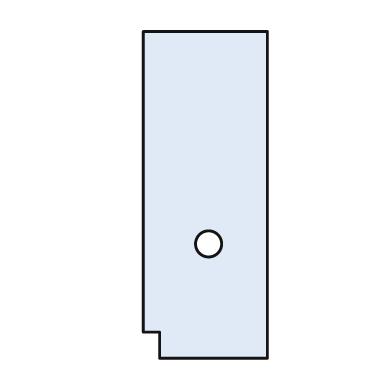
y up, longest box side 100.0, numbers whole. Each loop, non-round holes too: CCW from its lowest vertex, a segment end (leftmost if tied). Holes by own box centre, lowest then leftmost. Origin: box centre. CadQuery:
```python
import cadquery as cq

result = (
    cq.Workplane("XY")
    .moveTo(-14.0, -50.0)
    .lineTo(19.0, -50.0)
    .lineTo(19.0, 50.0)
    .lineTo(-19.0, 50.0)
    .lineTo(-19.0, -42.0)
    .lineTo(-14.0, -42.0)
    .close()
    .moveTo(1.0, -15.0)
    .circle(4.0)
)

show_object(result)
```